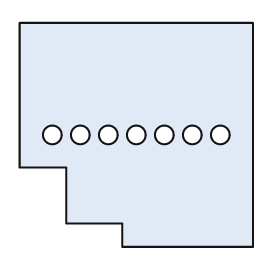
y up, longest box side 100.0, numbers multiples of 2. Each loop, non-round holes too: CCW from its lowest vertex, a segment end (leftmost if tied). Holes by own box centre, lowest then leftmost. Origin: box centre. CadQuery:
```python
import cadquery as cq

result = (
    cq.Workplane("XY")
    .moveTo(-6.0, -48.0)
    .lineTo(50.0, -48.0)
    .lineTo(50.0, 48.0)
    .lineTo(-50.0, 48.0)
    .lineTo(-50.0, -14.0)
    .lineTo(-30.0, -14.0)
    .lineTo(-30.0, -38.0)
    .lineTo(-6.0, -38.0)
    .close()
    .moveTo(-36.0, 0.0)
    .circle(4.0)
    .moveTo(-24.0, 0.0)
    .circle(4.0)
    .moveTo(-12.0, 0.0)
    .circle(4.0)
    .moveTo(0.0, 0.0)
    .circle(4.0)
    .moveTo(12.0, 0.0)
    .circle(4.0)
    .moveTo(24.0, 0.0)
    .circle(4.0)
    .moveTo(36.0, 0.0)
    .circle(4.0)
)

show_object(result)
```